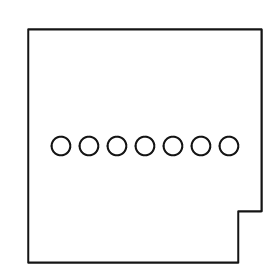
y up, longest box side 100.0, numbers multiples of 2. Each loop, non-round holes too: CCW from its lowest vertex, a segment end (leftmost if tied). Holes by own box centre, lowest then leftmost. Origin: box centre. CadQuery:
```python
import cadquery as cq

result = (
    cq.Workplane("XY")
    .moveTo(-50.0, -50.0)
    .lineTo(40.0, -50.0)
    .lineTo(40.0, -28.0)
    .lineTo(50.0, -28.0)
    .lineTo(50.0, 50.0)
    .lineTo(-50.0, 50.0)
    .close()
    .moveTo(-36.0, 0.0)
    .circle(4.0)
    .moveTo(-24.0, 0.0)
    .circle(4.0)
    .moveTo(-12.0, 0.0)
    .circle(4.0)
    .moveTo(0.0, 0.0)
    .circle(4.0)
    .moveTo(12.0, 0.0)
    .circle(4.0)
    .moveTo(24.0, 0.0)
    .circle(4.0)
    .moveTo(36.0, 0.0)
    .circle(4.0)
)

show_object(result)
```